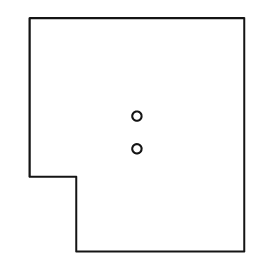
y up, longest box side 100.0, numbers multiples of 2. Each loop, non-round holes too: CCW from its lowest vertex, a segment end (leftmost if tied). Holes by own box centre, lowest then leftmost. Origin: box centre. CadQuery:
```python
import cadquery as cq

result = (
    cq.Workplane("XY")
    .moveTo(-26.0, -50.0)
    .lineTo(46.0, -50.0)
    .lineTo(46.0, 50.0)
    .lineTo(-46.0, 50.0)
    .lineTo(-46.0, -18.0)
    .lineTo(-26.0, -18.0)
    .close()
    .moveTo(0.0, -6.0)
    .circle(2.0)
    .moveTo(0.0, 8.0)
    .circle(2.0)
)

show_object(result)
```